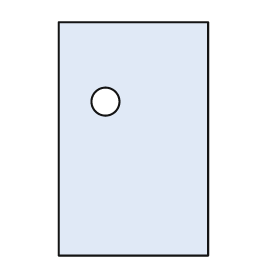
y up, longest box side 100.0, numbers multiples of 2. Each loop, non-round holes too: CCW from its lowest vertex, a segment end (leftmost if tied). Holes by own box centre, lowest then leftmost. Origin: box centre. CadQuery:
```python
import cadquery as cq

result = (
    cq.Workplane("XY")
    .moveTo(-32.0, -50.0)
    .lineTo(32.0, -50.0)
    .lineTo(32.0, 50.0)
    .lineTo(-32.0, 50.0)
    .close()
    .moveTo(-12.0, 16.0)
    .circle(6.0)
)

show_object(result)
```